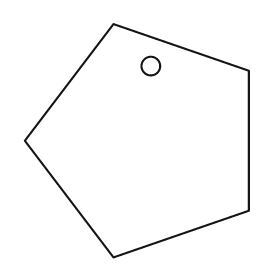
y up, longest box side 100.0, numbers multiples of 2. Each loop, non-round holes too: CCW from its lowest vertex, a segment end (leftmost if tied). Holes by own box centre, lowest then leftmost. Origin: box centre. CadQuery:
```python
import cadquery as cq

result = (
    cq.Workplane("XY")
    .moveTo(-10.0, -50.0)
    .lineTo(48.0, -30.0)
    .lineTo(48.0, 30.0)
    .lineTo(-10.0, 50.0)
    .lineTo(-48.0, 0.0)
    .close()
    .moveTo(6.0, 32.0)
    .circle(4.0)
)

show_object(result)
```